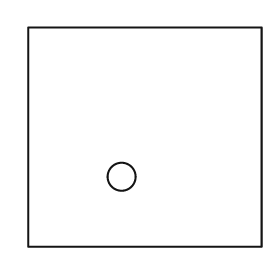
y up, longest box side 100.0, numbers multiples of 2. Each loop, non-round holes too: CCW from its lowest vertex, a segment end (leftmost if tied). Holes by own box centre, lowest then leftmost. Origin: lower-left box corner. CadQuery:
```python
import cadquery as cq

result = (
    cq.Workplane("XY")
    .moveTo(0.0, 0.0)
    .lineTo(100.0, 0.0)
    .lineTo(100.0, 94.0)
    .lineTo(0.0, 94.0)
    .close()
    .moveTo(40.0, 30.0)
    .circle(6.0)
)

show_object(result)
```